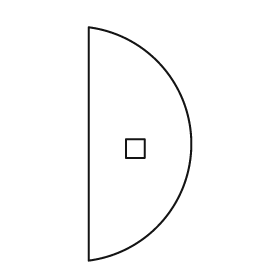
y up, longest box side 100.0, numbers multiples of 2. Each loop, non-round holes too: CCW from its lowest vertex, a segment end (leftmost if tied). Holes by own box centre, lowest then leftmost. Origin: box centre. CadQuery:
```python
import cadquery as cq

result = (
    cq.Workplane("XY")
    .moveTo(-22.0, -50.0)
    .threePointArc((22.0, 0.0), (-22.0, 50.0))
    .close()
    .moveTo(-6.0, -6.0)
    .lineTo(2.0, -6.0)
    .lineTo(2.0, 2.0)
    .lineTo(-6.0, 2.0)
    .close()
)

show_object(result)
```